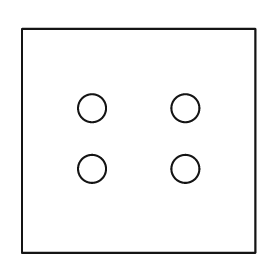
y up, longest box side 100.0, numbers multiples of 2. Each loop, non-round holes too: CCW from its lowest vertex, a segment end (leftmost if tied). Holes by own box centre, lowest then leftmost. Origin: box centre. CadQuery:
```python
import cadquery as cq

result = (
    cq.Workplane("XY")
    .moveTo(-50.0, -48.0)
    .lineTo(50.0, -48.0)
    .lineTo(50.0, 48.0)
    .lineTo(-50.0, 48.0)
    .close()
    .moveTo(-20.0, -12.0)
    .circle(6.0)
    .moveTo(20.0, -12.0)
    .circle(6.0)
    .moveTo(-20.0, 14.0)
    .circle(6.0)
    .moveTo(20.0, 14.0)
    .circle(6.0)
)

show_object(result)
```